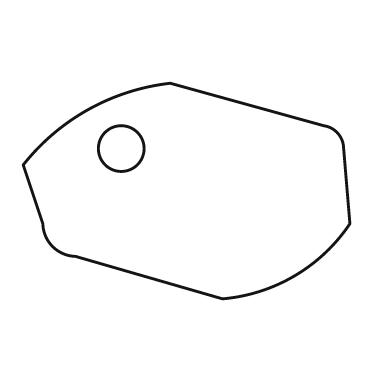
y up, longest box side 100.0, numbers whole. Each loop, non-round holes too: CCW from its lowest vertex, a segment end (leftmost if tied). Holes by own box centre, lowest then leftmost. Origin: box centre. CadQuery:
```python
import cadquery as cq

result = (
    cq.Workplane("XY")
    .moveTo(11.0, -33.0)
    .threePointArc((33.0, -26.0), (50.0, -10.0))
    .lineTo(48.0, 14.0)
    .threePointArc((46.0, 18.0), (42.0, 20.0))
    .lineTo(-5.0, 33.0)
    .threePointArc((-30.0, 25.0), (-50.0, 8.0))
    .lineTo(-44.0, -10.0)
    .threePointArc((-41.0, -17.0), (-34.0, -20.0))
    .close()
    .moveTo(-20.0, 13.0)
    .circle(7.0)
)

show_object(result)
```